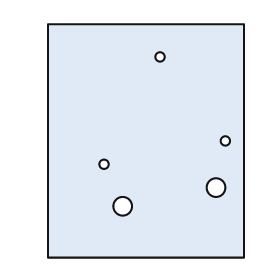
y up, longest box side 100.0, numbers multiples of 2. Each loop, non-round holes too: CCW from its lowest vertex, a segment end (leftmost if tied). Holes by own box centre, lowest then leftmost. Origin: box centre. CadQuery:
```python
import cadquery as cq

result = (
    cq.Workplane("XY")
    .moveTo(-42.0, -50.0)
    .lineTo(42.0, -50.0)
    .lineTo(42.0, 50.0)
    .lineTo(-42.0, 50.0)
    .close()
    .moveTo(-10.0, -28.0)
    .circle(4.0)
    .moveTo(30.0, -20.0)
    .circle(4.0)
    .moveTo(-18.0, -10.0)
    .circle(2.0)
    .moveTo(34.0, 0.0)
    .circle(2.0)
    .moveTo(6.0, 36.0)
    .circle(2.0)
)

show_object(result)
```